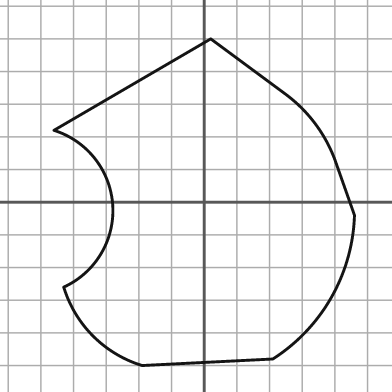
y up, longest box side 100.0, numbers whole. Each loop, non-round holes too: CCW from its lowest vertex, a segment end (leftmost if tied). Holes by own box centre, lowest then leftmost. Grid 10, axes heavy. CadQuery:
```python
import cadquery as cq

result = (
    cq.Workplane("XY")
    .moveTo(-19.0, -50.0)
    .lineTo(21.0, -48.0)
    .threePointArc((39.0, -29.0), (46.0, -4.0))
    .lineTo(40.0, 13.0)
    .threePointArc((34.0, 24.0), (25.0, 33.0))
    .lineTo(2.0, 50.0)
    .lineTo(-46.0, 22.0)
    .threePointArc((-28.0, -1.0), (-43.0, -26.0))
    .threePointArc((-34.0, -41.0), (-19.0, -50.0))
    .close()
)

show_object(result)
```